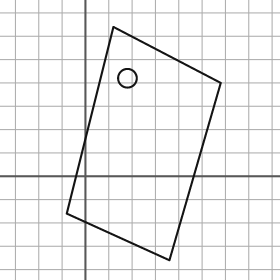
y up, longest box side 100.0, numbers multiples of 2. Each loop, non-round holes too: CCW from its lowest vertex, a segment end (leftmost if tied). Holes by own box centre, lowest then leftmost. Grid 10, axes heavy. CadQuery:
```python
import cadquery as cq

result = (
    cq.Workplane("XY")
    .moveTo(36.0, -36.0)
    .lineTo(58.0, 40.0)
    .lineTo(12.0, 64.0)
    .lineTo(-8.0, -16.0)
    .close()
    .moveTo(18.0, 42.0)
    .circle(4.0)
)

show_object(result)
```